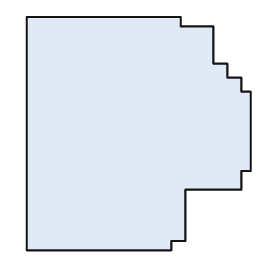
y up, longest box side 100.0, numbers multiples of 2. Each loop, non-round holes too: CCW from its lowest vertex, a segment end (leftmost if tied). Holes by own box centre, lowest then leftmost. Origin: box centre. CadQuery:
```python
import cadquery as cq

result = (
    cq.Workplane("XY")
    .moveTo(-48.0, -50.0)
    .lineTo(14.0, -50.0)
    .lineTo(14.0, -46.0)
    .lineTo(20.0, -46.0)
    .lineTo(20.0, -24.0)
    .lineTo(44.0, -24.0)
    .lineTo(44.0, -16.0)
    .lineTo(48.0, -16.0)
    .lineTo(48.0, 18.0)
    .lineTo(44.0, 18.0)
    .lineTo(44.0, 24.0)
    .lineTo(38.0, 24.0)
    .lineTo(38.0, 30.0)
    .lineTo(32.0, 30.0)
    .lineTo(32.0, 46.0)
    .lineTo(18.0, 46.0)
    .lineTo(18.0, 50.0)
    .lineTo(-48.0, 50.0)
    .close()
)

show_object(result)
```